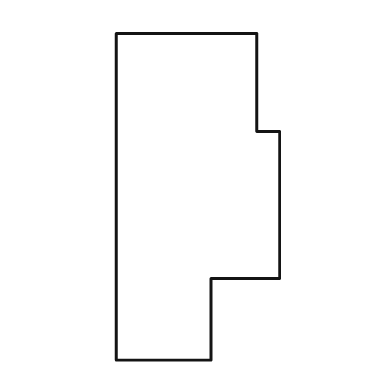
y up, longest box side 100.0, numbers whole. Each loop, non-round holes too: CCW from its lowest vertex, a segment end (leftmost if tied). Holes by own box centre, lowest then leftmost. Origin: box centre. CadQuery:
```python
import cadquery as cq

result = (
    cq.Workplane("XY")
    .moveTo(-25.0, -50.0)
    .lineTo(4.0, -50.0)
    .lineTo(4.0, -25.0)
    .lineTo(25.0, -25.0)
    .lineTo(25.0, 20.0)
    .lineTo(18.0, 20.0)
    .lineTo(18.0, 50.0)
    .lineTo(-25.0, 50.0)
    .close()
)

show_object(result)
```